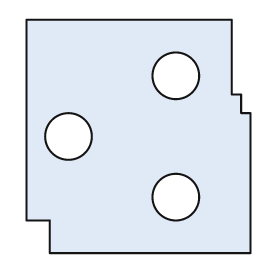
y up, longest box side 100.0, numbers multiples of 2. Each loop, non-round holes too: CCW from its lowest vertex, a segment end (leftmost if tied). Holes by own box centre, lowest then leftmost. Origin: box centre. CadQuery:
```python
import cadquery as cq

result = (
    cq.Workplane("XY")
    .moveTo(-38.0, -50.0)
    .lineTo(48.0, -50.0)
    .lineTo(48.0, 10.0)
    .lineTo(44.0, 10.0)
    .lineTo(44.0, 18.0)
    .lineTo(40.0, 18.0)
    .lineTo(40.0, 50.0)
    .lineTo(-48.0, 50.0)
    .lineTo(-48.0, -36.0)
    .lineTo(-38.0, -36.0)
    .close()
    .moveTo(16.0, -26.0)
    .circle(10.0)
    .moveTo(-30.0, 0.0)
    .circle(10.0)
    .moveTo(16.0, 26.0)
    .circle(10.0)
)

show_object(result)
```